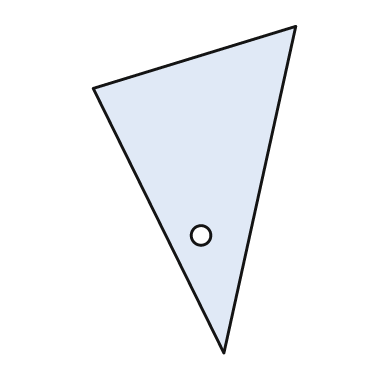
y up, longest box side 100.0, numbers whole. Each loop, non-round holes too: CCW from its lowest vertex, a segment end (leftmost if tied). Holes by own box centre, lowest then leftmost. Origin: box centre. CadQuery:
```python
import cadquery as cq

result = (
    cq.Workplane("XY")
    .moveTo(9.0, -50.0)
    .lineTo(31.0, 50.0)
    .lineTo(-31.0, 31.0)
    .close()
    .moveTo(2.0, -14.0)
    .circle(3.0)
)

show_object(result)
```